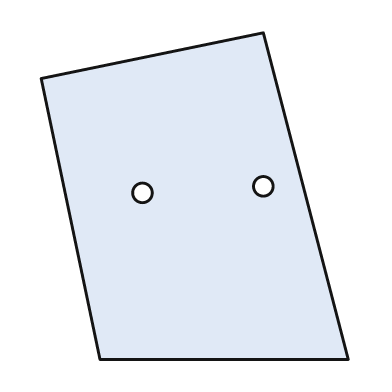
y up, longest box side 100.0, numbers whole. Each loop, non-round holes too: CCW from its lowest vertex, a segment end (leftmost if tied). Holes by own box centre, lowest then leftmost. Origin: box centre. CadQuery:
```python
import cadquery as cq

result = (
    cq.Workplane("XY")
    .moveTo(-29.0, -50.0)
    .lineTo(47.0, -50.0)
    .lineTo(21.0, 50.0)
    .lineTo(-47.0, 36.0)
    .close()
    .moveTo(-16.0, 1.0)
    .circle(3.0)
    .moveTo(21.0, 3.0)
    .circle(3.0)
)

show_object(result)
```